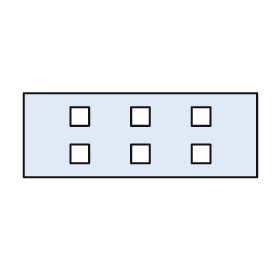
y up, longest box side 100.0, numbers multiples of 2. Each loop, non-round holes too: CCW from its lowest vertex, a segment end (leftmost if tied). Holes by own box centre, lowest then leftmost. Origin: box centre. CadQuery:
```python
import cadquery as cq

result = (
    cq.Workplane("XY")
    .moveTo(-50.0, -18.0)
    .lineTo(50.0, -18.0)
    .lineTo(50.0, 18.0)
    .lineTo(-50.0, 18.0)
    .close()
    .moveTo(-30.0, -12.0)
    .lineTo(-22.0, -12.0)
    .lineTo(-22.0, -4.0)
    .lineTo(-30.0, -4.0)
    .close()
    .moveTo(-4.0, -12.0)
    .lineTo(4.0, -12.0)
    .lineTo(4.0, -4.0)
    .lineTo(-4.0, -4.0)
    .close()
    .moveTo(22.0, -12.0)
    .lineTo(30.0, -12.0)
    .lineTo(30.0, -4.0)
    .lineTo(22.0, -4.0)
    .close()
    .moveTo(-30.0, 4.0)
    .lineTo(-22.0, 4.0)
    .lineTo(-22.0, 12.0)
    .lineTo(-30.0, 12.0)
    .close()
    .moveTo(-4.0, 4.0)
    .lineTo(4.0, 4.0)
    .lineTo(4.0, 12.0)
    .lineTo(-4.0, 12.0)
    .close()
    .moveTo(22.0, 4.0)
    .lineTo(30.0, 4.0)
    .lineTo(30.0, 12.0)
    .lineTo(22.0, 12.0)
    .close()
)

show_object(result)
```